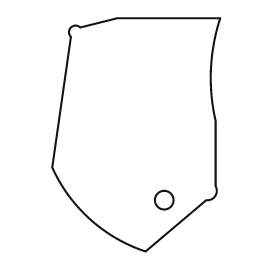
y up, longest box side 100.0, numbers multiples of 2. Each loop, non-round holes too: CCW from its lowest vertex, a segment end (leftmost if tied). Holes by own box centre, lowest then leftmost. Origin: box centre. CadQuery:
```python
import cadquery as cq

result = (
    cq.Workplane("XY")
    .moveTo(4.0, -50.0)
    .lineTo(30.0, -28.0)
    .threePointArc((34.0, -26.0), (34.0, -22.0))
    .lineTo(34.0, 6.0)
    .threePointArc((32.0, 28.0), (36.0, 50.0))
    .lineTo(-8.0, 50.0)
    .lineTo(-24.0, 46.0)
    .threePointArc((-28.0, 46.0), (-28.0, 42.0))
    .lineTo(-36.0, -14.0)
    .threePointArc((-20.0, -36.0), (4.0, -50.0))
    .close()
    .moveTo(12.0, -28.0)
    .circle(4.0)
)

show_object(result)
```